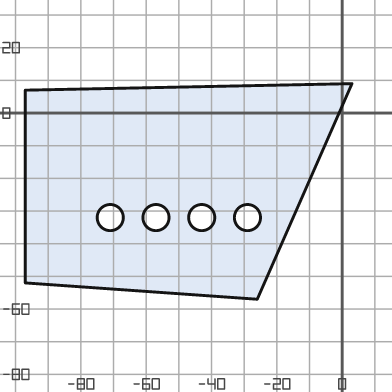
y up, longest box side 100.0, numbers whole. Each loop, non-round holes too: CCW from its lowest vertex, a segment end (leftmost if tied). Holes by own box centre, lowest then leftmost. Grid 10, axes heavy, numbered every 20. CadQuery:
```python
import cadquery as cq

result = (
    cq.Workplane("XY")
    .moveTo(-26.0, -57.0)
    .lineTo(3.0, 9.0)
    .lineTo(-97.0, 7.0)
    .lineTo(-97.0, -52.0)
    .close()
    .moveTo(-71.0, -32.0)
    .circle(4.0)
    .moveTo(-57.0, -32.0)
    .circle(4.0)
    .moveTo(-43.0, -32.0)
    .circle(4.0)
    .moveTo(-29.0, -32.0)
    .circle(4.0)
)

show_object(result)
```